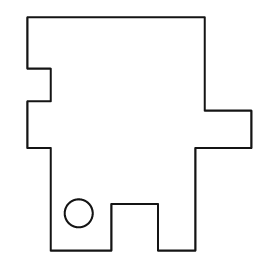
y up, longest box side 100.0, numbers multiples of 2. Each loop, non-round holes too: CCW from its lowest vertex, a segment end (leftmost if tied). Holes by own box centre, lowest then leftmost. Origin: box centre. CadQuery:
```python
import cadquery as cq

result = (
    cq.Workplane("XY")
    .moveTo(-38.0, -50.0)
    .lineTo(-12.0, -50.0)
    .lineTo(-12.0, -30.0)
    .lineTo(8.0, -30.0)
    .lineTo(8.0, -50.0)
    .lineTo(24.0, -50.0)
    .lineTo(24.0, -6.0)
    .lineTo(48.0, -6.0)
    .lineTo(48.0, 10.0)
    .lineTo(28.0, 10.0)
    .lineTo(28.0, 50.0)
    .lineTo(-48.0, 50.0)
    .lineTo(-48.0, 28.0)
    .lineTo(-38.0, 28.0)
    .lineTo(-38.0, 14.0)
    .lineTo(-48.0, 14.0)
    .lineTo(-48.0, -6.0)
    .lineTo(-38.0, -6.0)
    .close()
    .moveTo(-26.0, -34.0)
    .circle(6.0)
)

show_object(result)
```